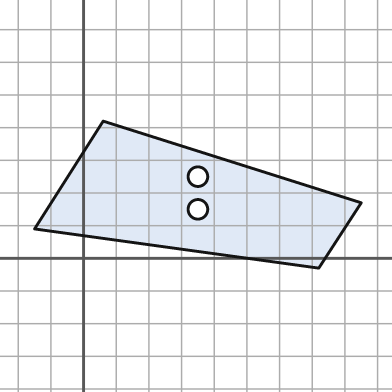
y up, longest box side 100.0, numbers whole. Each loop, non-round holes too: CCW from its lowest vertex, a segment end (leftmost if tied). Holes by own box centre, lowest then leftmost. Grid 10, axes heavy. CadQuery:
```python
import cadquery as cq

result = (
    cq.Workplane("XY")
    .moveTo(72.0, -3.0)
    .lineTo(85.0, 17.0)
    .lineTo(6.0, 42.0)
    .lineTo(-15.0, 9.0)
    .close()
    .moveTo(35.0, 15.0)
    .circle(3.0)
    .moveTo(35.0, 25.0)
    .circle(3.0)
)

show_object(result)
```